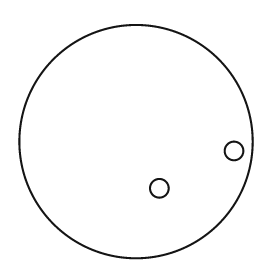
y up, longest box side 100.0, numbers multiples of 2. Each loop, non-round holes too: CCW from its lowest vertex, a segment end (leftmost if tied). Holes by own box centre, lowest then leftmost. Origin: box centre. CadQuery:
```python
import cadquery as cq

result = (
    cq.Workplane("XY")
    .moveTo(0.0, 0.0)
    .circle(50.0)
    .moveTo(10.0, -20.0)
    .circle(4.0)
    .moveTo(42.0, -4.0)
    .circle(4.0)
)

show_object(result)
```